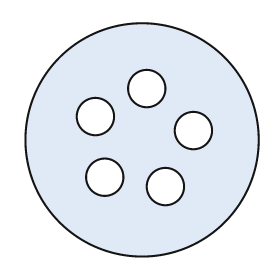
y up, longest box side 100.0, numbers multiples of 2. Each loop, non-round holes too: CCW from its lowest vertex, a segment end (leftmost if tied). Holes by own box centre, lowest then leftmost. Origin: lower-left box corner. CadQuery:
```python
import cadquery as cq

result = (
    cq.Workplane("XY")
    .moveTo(50.0, 50.0)
    .circle(50.0)
    .moveTo(60.0, 30.0)
    .circle(8.0)
    .moveTo(34.0, 34.0)
    .circle(8.0)
    .moveTo(72.0, 54.0)
    .circle(8.0)
    .moveTo(30.0, 60.0)
    .circle(8.0)
    .moveTo(52.0, 72.0)
    .circle(8.0)
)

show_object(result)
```